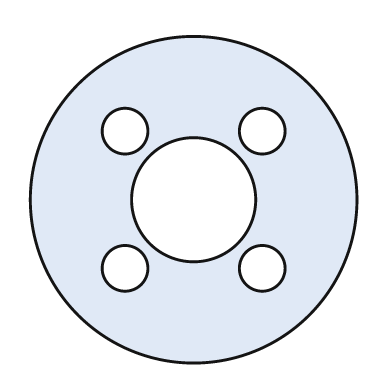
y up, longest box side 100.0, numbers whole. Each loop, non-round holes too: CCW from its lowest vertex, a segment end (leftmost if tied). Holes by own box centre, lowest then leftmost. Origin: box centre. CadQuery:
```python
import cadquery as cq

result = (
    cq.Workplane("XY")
    .moveTo(0.0, 0.0)
    .circle(50.0)
    .moveTo(-21.0, -21.0)
    .circle(7.0)
    .moveTo(21.0, -21.0)
    .circle(7.0)
    .moveTo(0.0, 0.0)
    .circle(19.0)
    .moveTo(-21.0, 21.0)
    .circle(7.0)
    .moveTo(21.0, 21.0)
    .circle(7.0)
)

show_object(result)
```